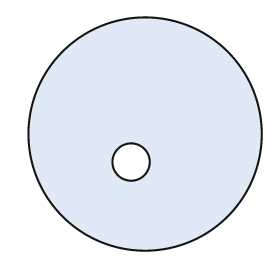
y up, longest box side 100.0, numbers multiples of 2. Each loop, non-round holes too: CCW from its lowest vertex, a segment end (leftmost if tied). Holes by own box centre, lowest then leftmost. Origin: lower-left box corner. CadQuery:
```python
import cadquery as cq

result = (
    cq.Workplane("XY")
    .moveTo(50.0, 50.0)
    .circle(50.0)
    .moveTo(44.0, 38.0)
    .circle(8.0)
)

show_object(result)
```